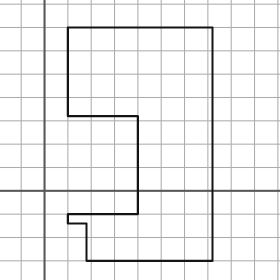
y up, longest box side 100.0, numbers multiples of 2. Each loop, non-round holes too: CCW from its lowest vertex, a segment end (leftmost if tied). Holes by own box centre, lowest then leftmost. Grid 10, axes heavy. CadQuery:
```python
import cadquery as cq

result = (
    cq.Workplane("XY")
    .moveTo(18.0, -30.0)
    .lineTo(72.0, -30.0)
    .lineTo(72.0, 70.0)
    .lineTo(10.0, 70.0)
    .lineTo(10.0, 32.0)
    .lineTo(40.0, 32.0)
    .lineTo(40.0, -10.0)
    .lineTo(10.0, -10.0)
    .lineTo(10.0, -14.0)
    .lineTo(18.0, -14.0)
    .close()
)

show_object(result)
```